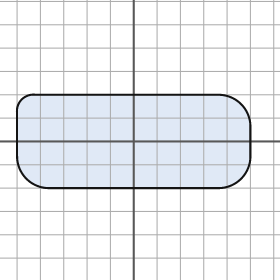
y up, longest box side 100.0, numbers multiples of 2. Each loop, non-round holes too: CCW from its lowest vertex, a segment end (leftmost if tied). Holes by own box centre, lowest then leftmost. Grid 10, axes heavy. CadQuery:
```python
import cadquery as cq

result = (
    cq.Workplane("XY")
    .moveTo(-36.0, -20.0)
    .lineTo(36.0, -20.0)
    .threePointArc((46.0, -16.0), (50.0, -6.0))
    .lineTo(50.0, 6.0)
    .threePointArc((46.0, 16.0), (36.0, 20.0))
    .lineTo(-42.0, 20.0)
    .threePointArc((-48.0, 18.0), (-50.0, 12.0))
    .lineTo(-50.0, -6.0)
    .threePointArc((-46.0, -16.0), (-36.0, -20.0))
    .close()
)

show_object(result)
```